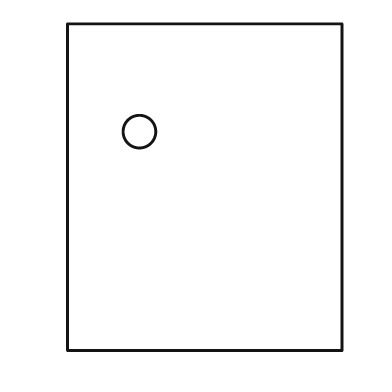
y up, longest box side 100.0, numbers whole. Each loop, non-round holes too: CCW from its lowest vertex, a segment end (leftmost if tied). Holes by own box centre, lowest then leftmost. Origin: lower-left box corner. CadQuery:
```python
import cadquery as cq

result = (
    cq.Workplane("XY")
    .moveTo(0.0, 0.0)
    .lineTo(84.0, 0.0)
    .lineTo(84.0, 100.0)
    .lineTo(0.0, 100.0)
    .close()
    .moveTo(22.0, 67.0)
    .circle(5.0)
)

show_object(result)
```